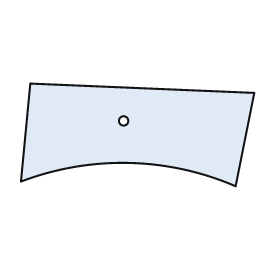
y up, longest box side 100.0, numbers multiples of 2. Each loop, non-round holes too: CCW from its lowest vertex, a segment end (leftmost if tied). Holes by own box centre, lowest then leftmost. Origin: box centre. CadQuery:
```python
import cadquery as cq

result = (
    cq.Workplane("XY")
    .moveTo(42.0, -22.0)
    .lineTo(50.0, 18.0)
    .lineTo(-46.0, 22.0)
    .lineTo(-50.0, -20.0)
    .threePointArc((-4.0, -12.0), (42.0, -22.0))
    .close()
    .moveTo(-6.0, 6.0)
    .circle(2.0)
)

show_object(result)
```